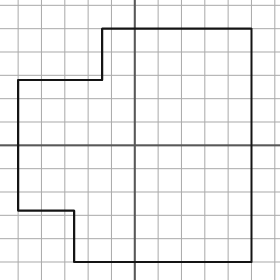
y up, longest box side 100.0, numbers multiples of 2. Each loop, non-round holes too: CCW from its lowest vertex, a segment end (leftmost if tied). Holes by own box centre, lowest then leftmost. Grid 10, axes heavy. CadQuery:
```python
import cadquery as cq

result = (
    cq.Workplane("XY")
    .moveTo(-26.0, -50.0)
    .lineTo(50.0, -50.0)
    .lineTo(50.0, 50.0)
    .lineTo(-14.0, 50.0)
    .lineTo(-14.0, 28.0)
    .lineTo(-50.0, 28.0)
    .lineTo(-50.0, -28.0)
    .lineTo(-26.0, -28.0)
    .close()
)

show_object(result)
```